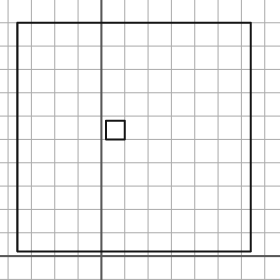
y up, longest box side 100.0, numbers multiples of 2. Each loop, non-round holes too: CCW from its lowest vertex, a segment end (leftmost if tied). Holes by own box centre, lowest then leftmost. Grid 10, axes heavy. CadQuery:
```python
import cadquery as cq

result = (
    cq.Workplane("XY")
    .moveTo(-36.0, 2.0)
    .lineTo(64.0, 2.0)
    .lineTo(64.0, 100.0)
    .lineTo(-36.0, 100.0)
    .close()
    .moveTo(2.0, 50.0)
    .lineTo(10.0, 50.0)
    .lineTo(10.0, 58.0)
    .lineTo(2.0, 58.0)
    .close()
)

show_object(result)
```